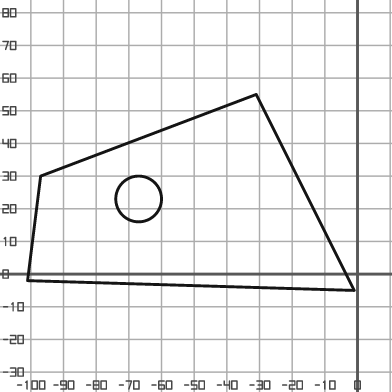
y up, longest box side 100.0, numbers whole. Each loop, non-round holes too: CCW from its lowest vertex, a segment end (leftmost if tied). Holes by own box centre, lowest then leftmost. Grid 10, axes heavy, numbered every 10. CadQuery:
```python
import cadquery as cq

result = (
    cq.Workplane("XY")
    .moveTo(-1.0, -5.0)
    .lineTo(-31.0, 55.0)
    .lineTo(-97.0, 30.0)
    .lineTo(-101.0, -2.0)
    .close()
    .moveTo(-67.0, 23.0)
    .circle(7.0)
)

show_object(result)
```